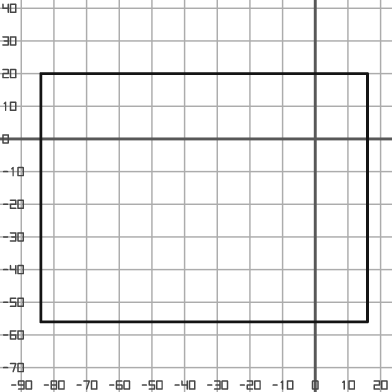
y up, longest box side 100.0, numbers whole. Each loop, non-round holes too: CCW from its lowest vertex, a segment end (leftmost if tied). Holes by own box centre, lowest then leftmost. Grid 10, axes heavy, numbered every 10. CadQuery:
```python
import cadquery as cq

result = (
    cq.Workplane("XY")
    .moveTo(-84.0, -56.0)
    .lineTo(16.0, -56.0)
    .lineTo(16.0, 20.0)
    .lineTo(-84.0, 20.0)
    .close()
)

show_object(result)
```